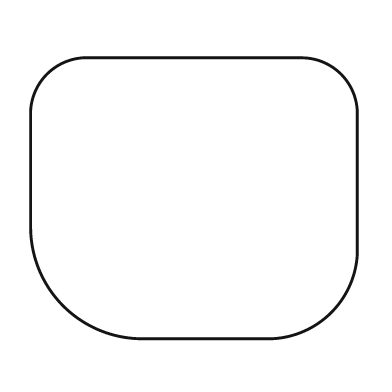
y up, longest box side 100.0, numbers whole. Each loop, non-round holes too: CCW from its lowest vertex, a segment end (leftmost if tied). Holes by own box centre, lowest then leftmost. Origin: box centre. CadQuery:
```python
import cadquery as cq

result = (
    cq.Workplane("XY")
    .moveTo(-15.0, -43.0)
    .lineTo(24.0, -43.0)
    .threePointArc((42.0, -35.0), (50.0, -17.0))
    .lineTo(50.0, 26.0)
    .threePointArc((45.0, 38.0), (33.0, 43.0))
    .lineTo(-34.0, 43.0)
    .threePointArc((-45.0, 38.0), (-50.0, 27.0))
    .lineTo(-50.0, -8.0)
    .threePointArc((-40.0, -33.0), (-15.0, -43.0))
    .close()
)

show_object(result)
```